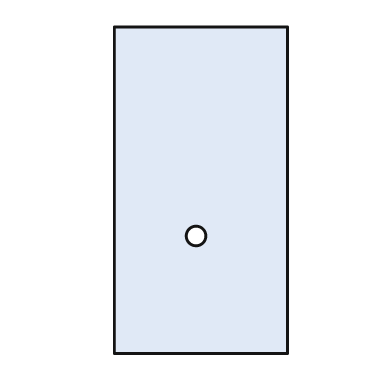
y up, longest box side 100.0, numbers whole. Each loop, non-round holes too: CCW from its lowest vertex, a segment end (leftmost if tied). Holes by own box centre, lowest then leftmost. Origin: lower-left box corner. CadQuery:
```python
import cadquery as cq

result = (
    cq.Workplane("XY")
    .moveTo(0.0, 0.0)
    .lineTo(53.0, 0.0)
    .lineTo(53.0, 100.0)
    .lineTo(0.0, 100.0)
    .close()
    .moveTo(25.0, 36.0)
    .circle(3.0)
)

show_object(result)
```